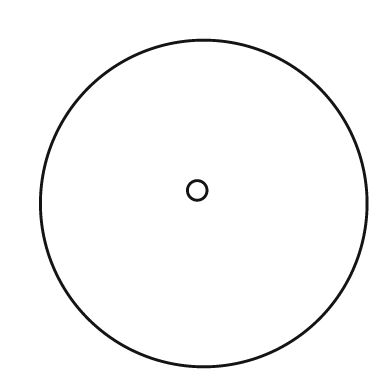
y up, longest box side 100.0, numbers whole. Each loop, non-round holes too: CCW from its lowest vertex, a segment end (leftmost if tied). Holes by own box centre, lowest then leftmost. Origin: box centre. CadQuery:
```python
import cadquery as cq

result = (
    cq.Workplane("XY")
    .moveTo(0.0, 0.0)
    .circle(50.0)
    .moveTo(-2.0, 4.0)
    .circle(3.0)
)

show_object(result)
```